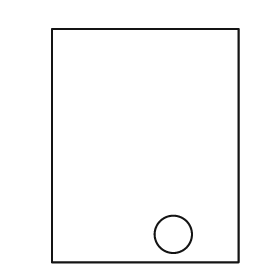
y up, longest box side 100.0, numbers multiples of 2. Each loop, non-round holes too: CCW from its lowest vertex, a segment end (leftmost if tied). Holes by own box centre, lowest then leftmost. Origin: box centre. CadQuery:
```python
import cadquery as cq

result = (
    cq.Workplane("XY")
    .moveTo(-40.0, -50.0)
    .lineTo(40.0, -50.0)
    .lineTo(40.0, 50.0)
    .lineTo(-40.0, 50.0)
    .close()
    .moveTo(12.0, -38.0)
    .circle(8.0)
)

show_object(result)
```